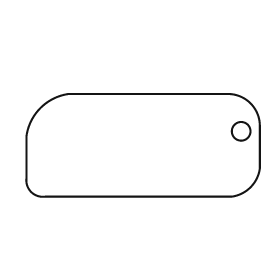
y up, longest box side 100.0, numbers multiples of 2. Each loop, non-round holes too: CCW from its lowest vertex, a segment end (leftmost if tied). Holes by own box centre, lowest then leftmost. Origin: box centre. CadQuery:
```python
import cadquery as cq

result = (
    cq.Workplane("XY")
    .moveTo(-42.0, -22.0)
    .lineTo(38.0, -22.0)
    .threePointArc((46.0, -18.0), (50.0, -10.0))
    .lineTo(50.0, 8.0)
    .threePointArc((46.0, 18.0), (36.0, 22.0))
    .lineTo(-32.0, 22.0)
    .threePointArc((-44.0, 16.0), (-50.0, 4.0))
    .lineTo(-50.0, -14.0)
    .threePointArc((-48.0, -20.0), (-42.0, -22.0))
    .close()
    .moveTo(42.0, 6.0)
    .circle(4.0)
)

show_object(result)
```